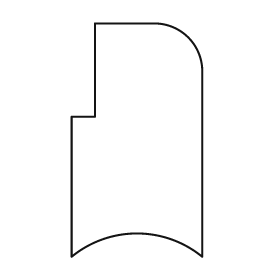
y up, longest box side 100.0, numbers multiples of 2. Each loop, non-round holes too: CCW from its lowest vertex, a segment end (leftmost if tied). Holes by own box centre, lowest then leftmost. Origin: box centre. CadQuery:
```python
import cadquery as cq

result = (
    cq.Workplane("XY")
    .moveTo(-28.0, -50.0)
    .threePointArc((0.0, -40.0), (28.0, -50.0))
    .lineTo(28.0, 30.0)
    .threePointArc((22.0, 44.0), (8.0, 50.0))
    .lineTo(-18.0, 50.0)
    .lineTo(-18.0, 10.0)
    .lineTo(-28.0, 10.0)
    .close()
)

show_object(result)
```